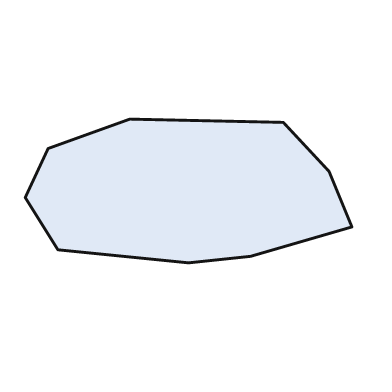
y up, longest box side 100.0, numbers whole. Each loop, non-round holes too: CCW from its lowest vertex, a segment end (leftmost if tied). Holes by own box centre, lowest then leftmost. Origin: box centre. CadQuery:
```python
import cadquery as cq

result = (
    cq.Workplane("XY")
    .moveTo(0.0, -22.0)
    .lineTo(19.0, -20.0)
    .lineTo(50.0, -11.0)
    .lineTo(43.0, 6.0)
    .lineTo(29.0, 21.0)
    .lineTo(-18.0, 22.0)
    .lineTo(-43.0, 13.0)
    .lineTo(-50.0, -2.0)
    .lineTo(-40.0, -18.0)
    .close()
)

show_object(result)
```